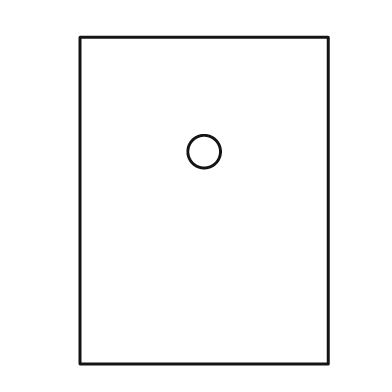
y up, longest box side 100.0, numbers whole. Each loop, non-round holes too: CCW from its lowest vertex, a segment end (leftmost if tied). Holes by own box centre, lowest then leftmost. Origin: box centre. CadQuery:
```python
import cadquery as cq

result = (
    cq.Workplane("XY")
    .moveTo(-38.0, -50.0)
    .lineTo(38.0, -50.0)
    .lineTo(38.0, 50.0)
    .lineTo(-38.0, 50.0)
    .close()
    .moveTo(0.0, 15.0)
    .circle(5.0)
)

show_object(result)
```